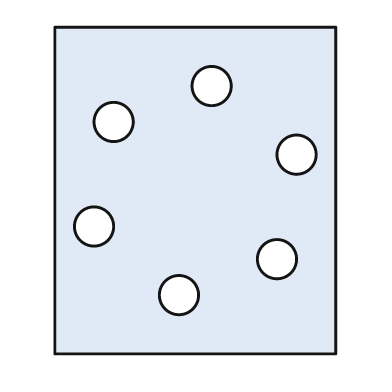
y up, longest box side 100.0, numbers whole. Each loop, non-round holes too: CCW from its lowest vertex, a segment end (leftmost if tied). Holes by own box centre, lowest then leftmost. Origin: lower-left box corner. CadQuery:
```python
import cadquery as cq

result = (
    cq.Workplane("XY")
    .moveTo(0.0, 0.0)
    .lineTo(86.0, 0.0)
    .lineTo(86.0, 100.0)
    .lineTo(0.0, 100.0)
    .close()
    .moveTo(38.0, 18.0)
    .circle(6.0)
    .moveTo(68.0, 29.0)
    .circle(6.0)
    .moveTo(12.0, 39.0)
    .circle(6.0)
    .moveTo(74.0, 61.0)
    .circle(6.0)
    .moveTo(18.0, 71.0)
    .circle(6.0)
    .moveTo(48.0, 82.0)
    .circle(6.0)
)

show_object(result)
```